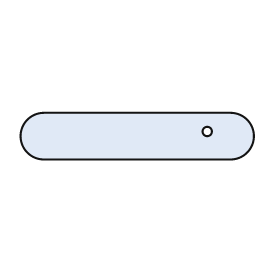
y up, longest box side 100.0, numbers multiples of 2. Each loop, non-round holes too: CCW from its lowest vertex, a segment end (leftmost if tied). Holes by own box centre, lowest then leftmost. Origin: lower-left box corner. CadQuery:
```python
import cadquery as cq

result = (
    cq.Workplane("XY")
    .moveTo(10.0, 0.0)
    .lineTo(90.0, 0.0)
    .threePointArc((100.0, 10.0), (90.0, 20.0))
    .lineTo(10.0, 20.0)
    .threePointArc((0.0, 10.0), (10.0, 0.0))
    .close()
    .moveTo(80.0, 12.0)
    .circle(2.0)
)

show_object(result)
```